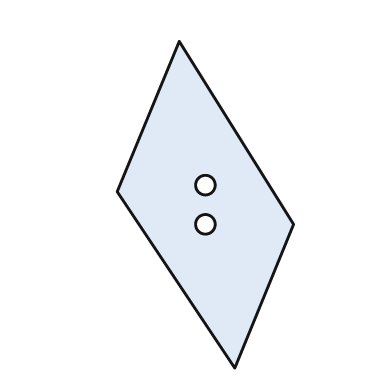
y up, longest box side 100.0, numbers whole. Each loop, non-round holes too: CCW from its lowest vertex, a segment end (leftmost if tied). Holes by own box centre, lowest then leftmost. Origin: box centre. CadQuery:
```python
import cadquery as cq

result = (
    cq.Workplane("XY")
    .moveTo(9.0, -50.0)
    .lineTo(27.0, -6.0)
    .lineTo(-8.0, 50.0)
    .lineTo(-27.0, 4.0)
    .close()
    .moveTo(0.0, -6.0)
    .circle(3.0)
    .moveTo(0.0, 6.0)
    .circle(3.0)
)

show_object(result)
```